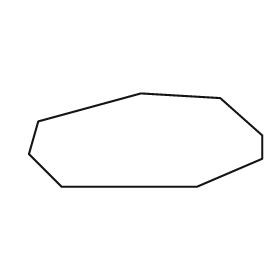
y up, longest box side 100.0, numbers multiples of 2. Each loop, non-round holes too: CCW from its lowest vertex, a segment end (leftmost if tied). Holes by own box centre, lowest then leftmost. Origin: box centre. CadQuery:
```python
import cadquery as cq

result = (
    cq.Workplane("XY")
    .moveTo(-36.0, -20.0)
    .lineTo(22.0, -20.0)
    .lineTo(50.0, -8.0)
    .lineTo(50.0, 2.0)
    .lineTo(32.0, 18.0)
    .lineTo(-2.0, 20.0)
    .lineTo(-46.0, 8.0)
    .lineTo(-50.0, -6.0)
    .close()
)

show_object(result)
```